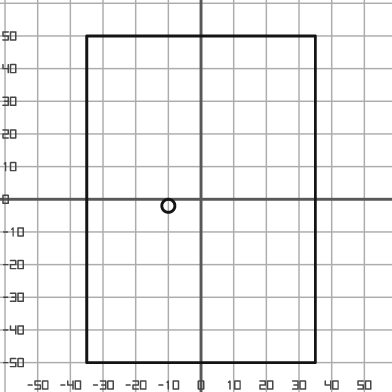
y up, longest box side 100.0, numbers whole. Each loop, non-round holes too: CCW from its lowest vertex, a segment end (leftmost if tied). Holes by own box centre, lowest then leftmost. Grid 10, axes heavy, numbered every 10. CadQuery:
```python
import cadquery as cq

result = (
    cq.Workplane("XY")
    .moveTo(-35.0, -50.0)
    .lineTo(35.0, -50.0)
    .lineTo(35.0, 50.0)
    .lineTo(-35.0, 50.0)
    .close()
    .moveTo(-10.0, -2.0)
    .circle(2.0)
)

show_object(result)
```